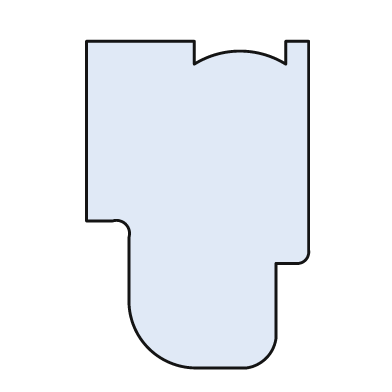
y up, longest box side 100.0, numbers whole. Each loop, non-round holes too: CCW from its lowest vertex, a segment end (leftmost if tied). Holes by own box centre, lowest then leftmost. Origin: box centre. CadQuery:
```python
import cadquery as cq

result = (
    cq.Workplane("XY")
    .moveTo(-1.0, -50.0)
    .lineTo(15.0, -50.0)
    .threePointArc((21.0, -47.0), (24.0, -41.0))
    .lineTo(24.0, -18.0)
    .lineTo(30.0, -18.0)
    .threePointArc((33.0, -17.0), (34.0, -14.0))
    .lineTo(34.0, 50.0)
    .lineTo(27.0, 50.0)
    .lineTo(27.0, 43.0)
    .threePointArc((13.0, 47.0), (-1.0, 43.0))
    .lineTo(-1.0, 50.0)
    .lineTo(-34.0, 50.0)
    .lineTo(-34.0, -5.0)
    .lineTo(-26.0, -5.0)
    .threePointArc((-22.0, -6.0), (-21.0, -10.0))
    .lineTo(-21.0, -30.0)
    .threePointArc((-15.0, -44.0), (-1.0, -50.0))
    .close()
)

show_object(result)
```